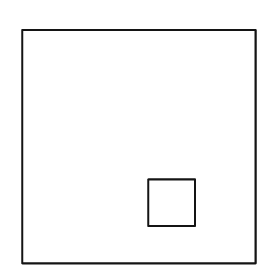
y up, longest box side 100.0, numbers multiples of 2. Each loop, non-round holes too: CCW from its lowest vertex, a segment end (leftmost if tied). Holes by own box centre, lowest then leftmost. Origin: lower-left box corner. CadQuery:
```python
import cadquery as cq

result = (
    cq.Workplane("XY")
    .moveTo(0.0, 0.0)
    .lineTo(100.0, 0.0)
    .lineTo(100.0, 100.0)
    .lineTo(0.0, 100.0)
    .close()
    .moveTo(54.0, 16.0)
    .lineTo(74.0, 16.0)
    .lineTo(74.0, 36.0)
    .lineTo(54.0, 36.0)
    .close()
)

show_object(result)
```